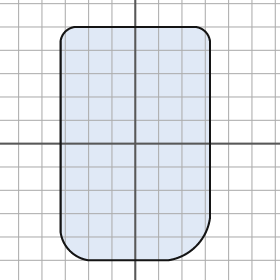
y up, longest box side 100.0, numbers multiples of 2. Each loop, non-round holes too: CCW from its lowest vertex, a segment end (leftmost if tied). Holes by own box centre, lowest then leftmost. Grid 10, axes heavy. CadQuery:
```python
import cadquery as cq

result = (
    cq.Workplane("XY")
    .moveTo(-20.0, -50.0)
    .lineTo(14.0, -50.0)
    .threePointArc((26.0, -44.0), (32.0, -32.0))
    .lineTo(32.0, 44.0)
    .threePointArc((30.0, 48.0), (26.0, 50.0))
    .lineTo(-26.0, 50.0)
    .threePointArc((-30.0, 48.0), (-32.0, 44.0))
    .lineTo(-32.0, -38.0)
    .threePointArc((-28.0, -46.0), (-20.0, -50.0))
    .close()
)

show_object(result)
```